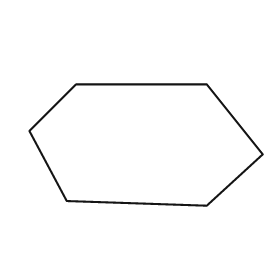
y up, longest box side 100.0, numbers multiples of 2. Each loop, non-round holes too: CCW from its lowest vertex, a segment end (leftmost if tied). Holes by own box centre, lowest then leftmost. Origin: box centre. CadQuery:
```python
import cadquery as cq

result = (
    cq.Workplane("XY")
    .moveTo(26.0, -26.0)
    .lineTo(50.0, -4.0)
    .lineTo(26.0, 26.0)
    .lineTo(-30.0, 26.0)
    .lineTo(-50.0, 6.0)
    .lineTo(-34.0, -24.0)
    .close()
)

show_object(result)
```